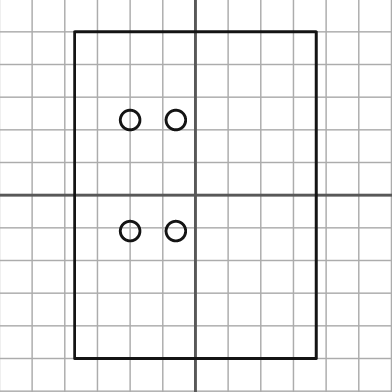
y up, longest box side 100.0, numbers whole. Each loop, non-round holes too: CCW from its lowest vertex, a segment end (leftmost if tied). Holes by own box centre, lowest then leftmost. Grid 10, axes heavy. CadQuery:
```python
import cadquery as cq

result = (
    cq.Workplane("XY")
    .moveTo(-37.0, -50.0)
    .lineTo(37.0, -50.0)
    .lineTo(37.0, 50.0)
    .lineTo(-37.0, 50.0)
    .close()
    .moveTo(-20.0, -11.0)
    .circle(3.0)
    .moveTo(-6.0, -11.0)
    .circle(3.0)
    .moveTo(-20.0, 23.0)
    .circle(3.0)
    .moveTo(-6.0, 23.0)
    .circle(3.0)
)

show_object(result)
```